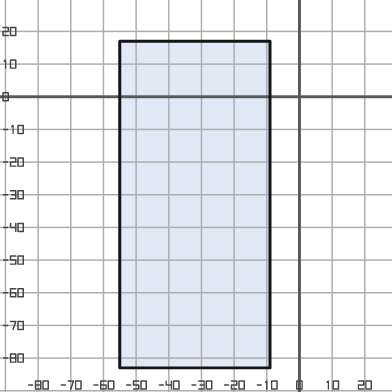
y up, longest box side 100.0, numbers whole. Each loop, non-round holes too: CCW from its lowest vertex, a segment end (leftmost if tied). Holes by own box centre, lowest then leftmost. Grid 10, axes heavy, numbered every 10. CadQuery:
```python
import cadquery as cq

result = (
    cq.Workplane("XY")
    .moveTo(-55.0, -83.0)
    .lineTo(-9.0, -83.0)
    .lineTo(-9.0, 17.0)
    .lineTo(-55.0, 17.0)
    .close()
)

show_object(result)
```